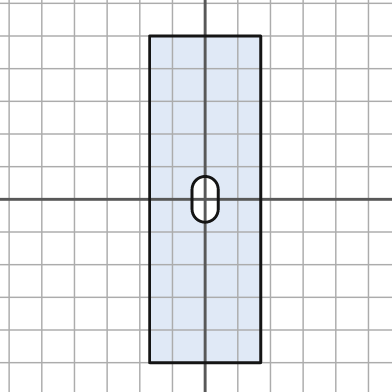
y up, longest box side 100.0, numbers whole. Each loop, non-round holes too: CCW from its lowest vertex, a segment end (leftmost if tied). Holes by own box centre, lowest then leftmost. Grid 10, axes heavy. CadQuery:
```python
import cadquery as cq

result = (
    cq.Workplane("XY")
    .moveTo(-17.0, -50.0)
    .lineTo(17.0, -50.0)
    .lineTo(17.0, 50.0)
    .lineTo(-17.0, 50.0)
    .close()
    .moveTo(-4.0, -3.0)
    .threePointArc((0.0, -7.0), (4.0, -3.0))
    .lineTo(4.0, 3.0)
    .threePointArc((0.0, 7.0), (-4.0, 3.0))
    .close()
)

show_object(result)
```